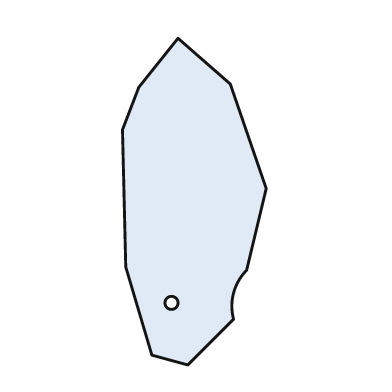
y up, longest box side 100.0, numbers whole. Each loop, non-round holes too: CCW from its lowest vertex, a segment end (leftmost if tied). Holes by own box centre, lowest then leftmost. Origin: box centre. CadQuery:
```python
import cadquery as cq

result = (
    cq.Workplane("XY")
    .moveTo(-2.0, -50.0)
    .lineTo(12.0, -36.0)
    .threePointArc((12.0, -28.0), (16.0, -21.0))
    .lineTo(22.0, 4.0)
    .lineTo(11.0, 36.0)
    .lineTo(-5.0, 50.0)
    .lineTo(-17.0, 35.0)
    .lineTo(-22.0, 22.0)
    .lineTo(-21.0, -20.0)
    .lineTo(-13.0, -47.0)
    .close()
    .moveTo(-7.0, -31.0)
    .circle(2.0)
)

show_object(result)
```